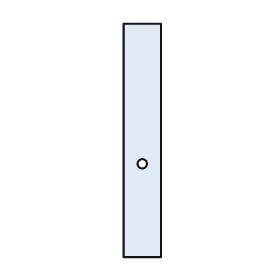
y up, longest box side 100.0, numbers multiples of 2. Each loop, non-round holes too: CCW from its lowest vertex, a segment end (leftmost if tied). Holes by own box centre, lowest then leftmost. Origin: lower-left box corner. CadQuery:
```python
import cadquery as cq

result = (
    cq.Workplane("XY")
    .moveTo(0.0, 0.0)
    .lineTo(16.0, 0.0)
    .lineTo(16.0, 100.0)
    .lineTo(0.0, 100.0)
    .close()
    .moveTo(8.0, 40.0)
    .circle(2.0)
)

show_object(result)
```